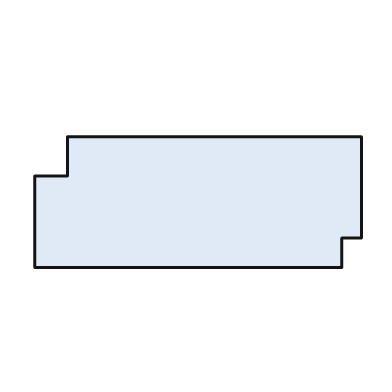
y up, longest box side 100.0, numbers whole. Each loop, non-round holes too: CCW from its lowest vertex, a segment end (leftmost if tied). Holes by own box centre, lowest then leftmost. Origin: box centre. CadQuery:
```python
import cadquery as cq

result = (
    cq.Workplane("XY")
    .moveTo(-50.0, -20.0)
    .lineTo(44.0, -20.0)
    .lineTo(44.0, -11.0)
    .lineTo(50.0, -11.0)
    .lineTo(50.0, 20.0)
    .lineTo(-40.0, 20.0)
    .lineTo(-40.0, 8.0)
    .lineTo(-50.0, 8.0)
    .close()
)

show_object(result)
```